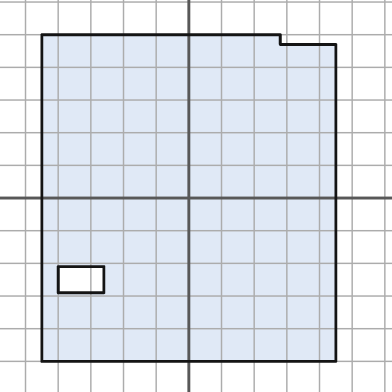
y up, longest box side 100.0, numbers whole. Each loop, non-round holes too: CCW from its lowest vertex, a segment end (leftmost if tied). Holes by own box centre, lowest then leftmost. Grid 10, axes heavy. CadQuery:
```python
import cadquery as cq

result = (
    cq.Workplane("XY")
    .moveTo(-45.0, -50.0)
    .lineTo(45.0, -50.0)
    .lineTo(45.0, 47.0)
    .lineTo(28.0, 47.0)
    .lineTo(28.0, 50.0)
    .lineTo(-45.0, 50.0)
    .close()
    .moveTo(-40.0, -29.0)
    .lineTo(-26.0, -29.0)
    .lineTo(-26.0, -21.0)
    .lineTo(-40.0, -21.0)
    .close()
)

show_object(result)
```